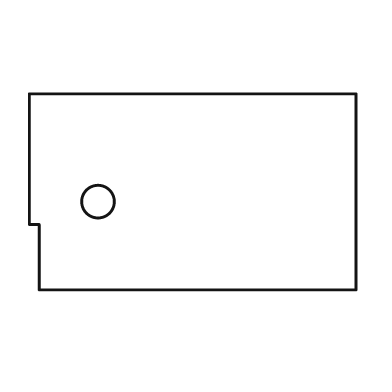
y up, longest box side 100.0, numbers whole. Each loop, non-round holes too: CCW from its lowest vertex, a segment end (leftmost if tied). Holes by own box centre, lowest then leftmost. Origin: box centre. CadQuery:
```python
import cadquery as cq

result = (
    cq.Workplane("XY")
    .moveTo(-47.0, -30.0)
    .lineTo(50.0, -30.0)
    .lineTo(50.0, 30.0)
    .lineTo(-50.0, 30.0)
    .lineTo(-50.0, -10.0)
    .lineTo(-47.0, -10.0)
    .close()
    .moveTo(-29.0, -3.0)
    .circle(5.0)
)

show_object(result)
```